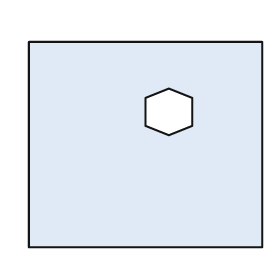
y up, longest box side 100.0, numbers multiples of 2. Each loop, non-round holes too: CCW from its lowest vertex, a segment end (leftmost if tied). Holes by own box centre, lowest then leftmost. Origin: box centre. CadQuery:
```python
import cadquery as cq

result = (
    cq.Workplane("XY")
    .moveTo(-50.0, -44.0)
    .lineTo(50.0, -44.0)
    .lineTo(50.0, 44.0)
    .lineTo(-50.0, 44.0)
    .close()
    .moveTo(10.0, 4.0)
    .lineTo(20.0, 8.0)
    .lineTo(20.0, 20.0)
    .lineTo(10.0, 24.0)
    .lineTo(0.0, 20.0)
    .lineTo(0.0, 8.0)
    .close()
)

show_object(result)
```